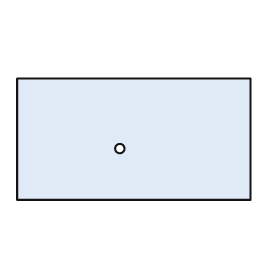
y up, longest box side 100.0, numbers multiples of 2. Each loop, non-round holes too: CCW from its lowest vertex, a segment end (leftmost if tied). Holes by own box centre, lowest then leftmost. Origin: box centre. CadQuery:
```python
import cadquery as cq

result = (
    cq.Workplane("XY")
    .moveTo(-50.0, -26.0)
    .lineTo(50.0, -26.0)
    .lineTo(50.0, 26.0)
    .lineTo(-50.0, 26.0)
    .close()
    .moveTo(-6.0, -4.0)
    .circle(2.0)
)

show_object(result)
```